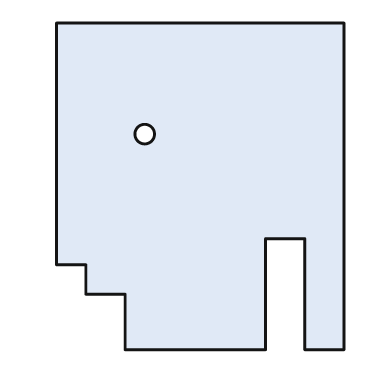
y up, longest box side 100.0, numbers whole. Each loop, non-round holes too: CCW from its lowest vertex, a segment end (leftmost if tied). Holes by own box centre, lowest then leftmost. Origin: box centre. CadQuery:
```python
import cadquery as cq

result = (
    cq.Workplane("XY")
    .moveTo(-23.0, -50.0)
    .lineTo(20.0, -50.0)
    .lineTo(20.0, -16.0)
    .lineTo(32.0, -16.0)
    .lineTo(32.0, -50.0)
    .lineTo(44.0, -50.0)
    .lineTo(44.0, 50.0)
    .lineTo(-44.0, 50.0)
    .lineTo(-44.0, -24.0)
    .lineTo(-35.0, -24.0)
    .lineTo(-35.0, -33.0)
    .lineTo(-23.0, -33.0)
    .close()
    .moveTo(-17.0, 16.0)
    .circle(3.0)
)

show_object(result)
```